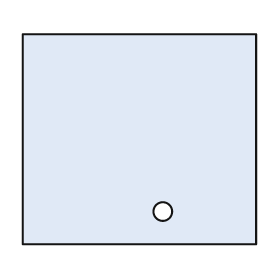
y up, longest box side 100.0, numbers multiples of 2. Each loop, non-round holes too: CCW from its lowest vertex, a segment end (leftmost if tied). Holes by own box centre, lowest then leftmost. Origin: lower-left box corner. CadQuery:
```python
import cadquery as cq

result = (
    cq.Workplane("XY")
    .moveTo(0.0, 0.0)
    .lineTo(100.0, 0.0)
    .lineTo(100.0, 90.0)
    .lineTo(0.0, 90.0)
    .close()
    .moveTo(60.0, 14.0)
    .circle(4.0)
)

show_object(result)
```